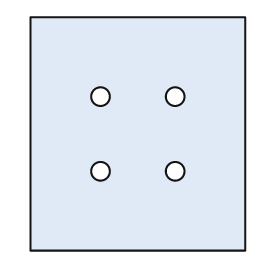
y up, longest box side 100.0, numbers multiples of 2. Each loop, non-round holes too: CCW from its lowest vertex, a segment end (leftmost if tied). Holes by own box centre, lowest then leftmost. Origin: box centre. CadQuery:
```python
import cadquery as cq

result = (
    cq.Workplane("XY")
    .moveTo(-46.0, -50.0)
    .lineTo(46.0, -50.0)
    .lineTo(46.0, 50.0)
    .lineTo(-46.0, 50.0)
    .close()
    .moveTo(-16.0, -16.0)
    .circle(4.0)
    .moveTo(16.0, -16.0)
    .circle(4.0)
    .moveTo(-16.0, 16.0)
    .circle(4.0)
    .moveTo(16.0, 16.0)
    .circle(4.0)
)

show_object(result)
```